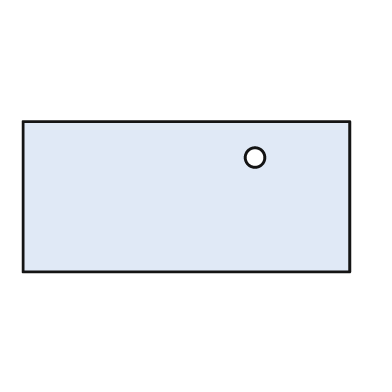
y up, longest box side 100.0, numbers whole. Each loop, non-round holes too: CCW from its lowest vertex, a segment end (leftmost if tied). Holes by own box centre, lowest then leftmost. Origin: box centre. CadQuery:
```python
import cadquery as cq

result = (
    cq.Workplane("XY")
    .moveTo(-50.0, -23.0)
    .lineTo(50.0, -23.0)
    .lineTo(50.0, 23.0)
    .lineTo(-50.0, 23.0)
    .close()
    .moveTo(21.0, 12.0)
    .circle(3.0)
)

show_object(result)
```